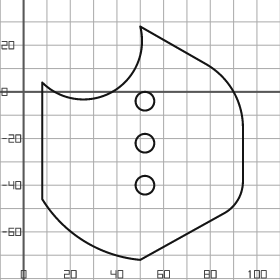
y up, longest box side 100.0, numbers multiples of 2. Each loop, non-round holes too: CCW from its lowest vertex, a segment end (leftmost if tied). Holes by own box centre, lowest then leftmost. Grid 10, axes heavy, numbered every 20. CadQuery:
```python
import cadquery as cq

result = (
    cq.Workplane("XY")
    .moveTo(50.0, -72.0)
    .lineTo(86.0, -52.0)
    .threePointArc((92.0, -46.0), (94.0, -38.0))
    .lineTo(94.0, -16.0)
    .threePointArc((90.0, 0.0), (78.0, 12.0))
    .lineTo(50.0, 28.0)
    .threePointArc((38.0, 0.0), (8.0, 4.0))
    .lineTo(8.0, -46.0)
    .threePointArc((26.0, -64.0), (50.0, -72.0))
    .close()
    .moveTo(52.0, -40.0)
    .circle(4.0)
    .moveTo(52.0, -22.0)
    .circle(4.0)
    .moveTo(52.0, -4.0)
    .circle(4.0)
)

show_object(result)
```